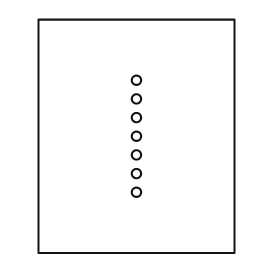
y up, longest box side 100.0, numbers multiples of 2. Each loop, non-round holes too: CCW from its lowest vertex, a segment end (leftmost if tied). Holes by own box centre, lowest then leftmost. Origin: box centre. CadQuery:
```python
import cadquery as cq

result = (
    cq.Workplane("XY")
    .moveTo(-42.0, -50.0)
    .lineTo(42.0, -50.0)
    .lineTo(42.0, 50.0)
    .lineTo(-42.0, 50.0)
    .close()
    .moveTo(0.0, -24.0)
    .circle(2.0)
    .moveTo(0.0, -16.0)
    .circle(2.0)
    .moveTo(0.0, -8.0)
    .circle(2.0)
    .moveTo(0.0, 0.0)
    .circle(2.0)
    .moveTo(0.0, 8.0)
    .circle(2.0)
    .moveTo(0.0, 16.0)
    .circle(2.0)
    .moveTo(0.0, 24.0)
    .circle(2.0)
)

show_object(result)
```